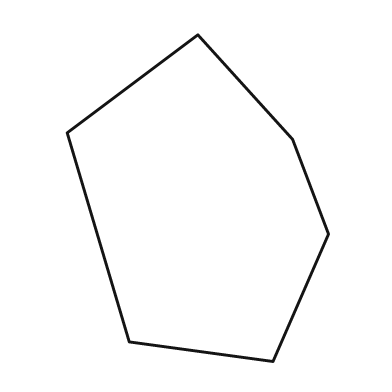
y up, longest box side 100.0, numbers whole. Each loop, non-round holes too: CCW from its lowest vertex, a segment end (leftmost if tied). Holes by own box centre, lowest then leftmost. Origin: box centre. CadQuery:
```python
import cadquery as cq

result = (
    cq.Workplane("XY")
    .moveTo(23.0, -50.0)
    .lineTo(40.0, -11.0)
    .lineTo(29.0, 18.0)
    .lineTo(0.0, 50.0)
    .lineTo(-40.0, 20.0)
    .lineTo(-21.0, -44.0)
    .close()
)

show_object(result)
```